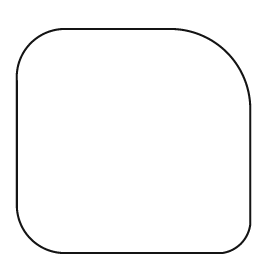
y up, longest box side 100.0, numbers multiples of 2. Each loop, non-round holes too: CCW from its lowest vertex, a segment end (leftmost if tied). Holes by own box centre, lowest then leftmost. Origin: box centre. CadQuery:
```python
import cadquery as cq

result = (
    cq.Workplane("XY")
    .moveTo(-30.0, -48.0)
    .lineTo(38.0, -48.0)
    .threePointArc((46.0, -44.0), (50.0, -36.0))
    .lineTo(50.0, 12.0)
    .threePointArc((40.0, 38.0), (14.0, 48.0))
    .lineTo(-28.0, 48.0)
    .threePointArc((-44.0, 42.0), (-50.0, 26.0))
    .lineTo(-50.0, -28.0)
    .threePointArc((-44.0, -42.0), (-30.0, -48.0))
    .close()
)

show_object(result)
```